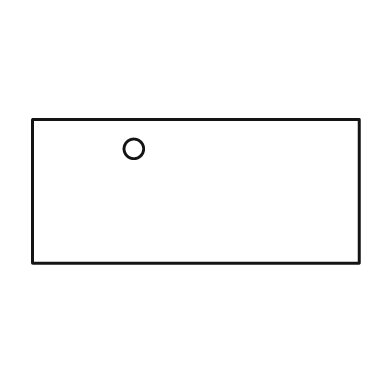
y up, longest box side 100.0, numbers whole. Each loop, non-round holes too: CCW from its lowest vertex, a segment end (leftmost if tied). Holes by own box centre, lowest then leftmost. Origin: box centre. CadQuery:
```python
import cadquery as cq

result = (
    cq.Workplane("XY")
    .moveTo(-50.0, -22.0)
    .lineTo(50.0, -22.0)
    .lineTo(50.0, 22.0)
    .lineTo(-50.0, 22.0)
    .close()
    .moveTo(-19.0, 13.0)
    .circle(3.0)
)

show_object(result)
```